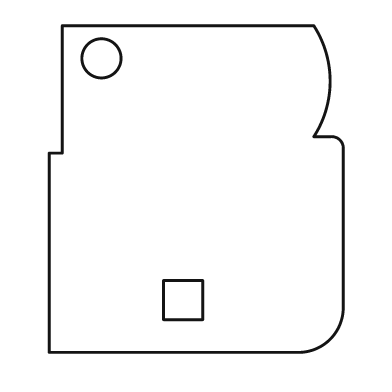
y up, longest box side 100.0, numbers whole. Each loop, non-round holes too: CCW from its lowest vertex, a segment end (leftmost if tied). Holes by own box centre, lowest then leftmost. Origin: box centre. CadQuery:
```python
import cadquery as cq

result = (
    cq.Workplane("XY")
    .moveTo(-45.0, -50.0)
    .lineTo(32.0, -50.0)
    .threePointArc((41.0, -46.0), (45.0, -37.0))
    .lineTo(45.0, 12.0)
    .threePointArc((44.0, 15.0), (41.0, 16.0))
    .lineTo(36.0, 16.0)
    .threePointArc((41.0, 33.0), (36.0, 50.0))
    .lineTo(-41.0, 50.0)
    .lineTo(-41.0, 11.0)
    .lineTo(-45.0, 11.0)
    .close()
    .moveTo(-10.0, -40.0)
    .lineTo(2.0, -40.0)
    .lineTo(2.0, -28.0)
    .lineTo(-10.0, -28.0)
    .close()
    .moveTo(-29.0, 40.0)
    .circle(6.0)
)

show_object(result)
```